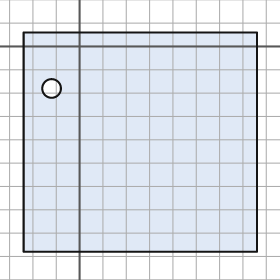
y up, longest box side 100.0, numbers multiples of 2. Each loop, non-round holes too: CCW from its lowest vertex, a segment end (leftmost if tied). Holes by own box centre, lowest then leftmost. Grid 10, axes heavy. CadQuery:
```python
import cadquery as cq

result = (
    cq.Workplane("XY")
    .moveTo(-24.0, -88.0)
    .lineTo(76.0, -88.0)
    .lineTo(76.0, 6.0)
    .lineTo(-24.0, 6.0)
    .close()
    .moveTo(-12.0, -18.0)
    .circle(4.0)
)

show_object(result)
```